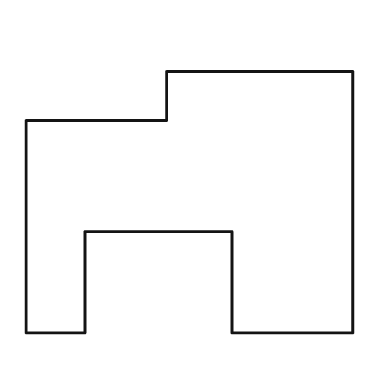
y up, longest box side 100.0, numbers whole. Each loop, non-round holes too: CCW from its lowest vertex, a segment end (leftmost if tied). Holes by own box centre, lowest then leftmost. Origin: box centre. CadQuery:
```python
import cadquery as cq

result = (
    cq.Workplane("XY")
    .moveTo(-50.0, -40.0)
    .lineTo(-32.0, -40.0)
    .lineTo(-32.0, -9.0)
    .lineTo(13.0, -9.0)
    .lineTo(13.0, -40.0)
    .lineTo(50.0, -40.0)
    .lineTo(50.0, 40.0)
    .lineTo(-7.0, 40.0)
    .lineTo(-7.0, 25.0)
    .lineTo(-50.0, 25.0)
    .close()
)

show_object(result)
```